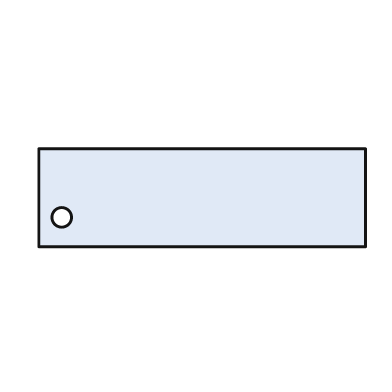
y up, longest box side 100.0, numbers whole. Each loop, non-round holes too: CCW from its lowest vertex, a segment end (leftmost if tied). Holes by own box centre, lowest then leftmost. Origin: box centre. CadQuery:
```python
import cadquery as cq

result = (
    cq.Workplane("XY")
    .moveTo(-50.0, -15.0)
    .lineTo(50.0, -15.0)
    .lineTo(50.0, 15.0)
    .lineTo(-50.0, 15.0)
    .close()
    .moveTo(-43.0, -6.0)
    .circle(3.0)
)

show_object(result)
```